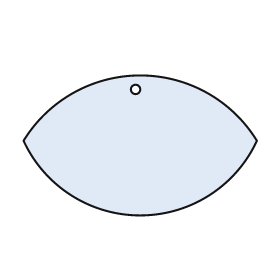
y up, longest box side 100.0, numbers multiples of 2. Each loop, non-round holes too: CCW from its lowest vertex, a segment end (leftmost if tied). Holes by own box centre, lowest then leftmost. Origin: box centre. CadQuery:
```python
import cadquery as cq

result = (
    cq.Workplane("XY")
    .moveTo(-50.0, 2.0)
    .threePointArc((0.0, -30.0), (50.0, 2.0))
    .threePointArc((0.0, 30.0), (-50.0, 2.0))
    .close()
    .moveTo(-2.0, 24.0)
    .circle(2.0)
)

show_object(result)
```